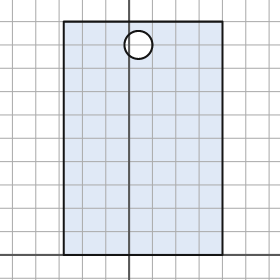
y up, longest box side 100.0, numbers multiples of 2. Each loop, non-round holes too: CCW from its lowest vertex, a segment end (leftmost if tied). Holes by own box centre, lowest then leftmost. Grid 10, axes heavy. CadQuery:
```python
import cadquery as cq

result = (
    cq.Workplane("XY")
    .moveTo(-28.0, 0.0)
    .lineTo(40.0, 0.0)
    .lineTo(40.0, 100.0)
    .lineTo(-28.0, 100.0)
    .close()
    .moveTo(4.0, 90.0)
    .circle(6.0)
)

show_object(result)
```